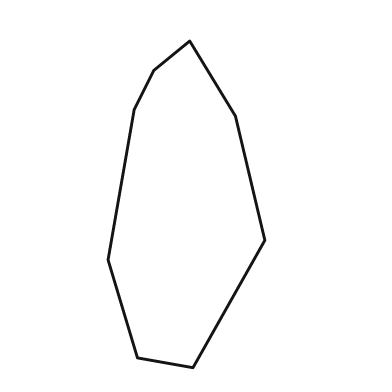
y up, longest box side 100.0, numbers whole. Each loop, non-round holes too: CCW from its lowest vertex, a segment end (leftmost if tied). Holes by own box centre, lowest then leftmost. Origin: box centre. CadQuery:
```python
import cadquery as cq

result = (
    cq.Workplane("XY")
    .moveTo(2.0, -50.0)
    .lineTo(24.0, -11.0)
    .lineTo(15.0, 27.0)
    .lineTo(1.0, 50.0)
    .lineTo(-10.0, 41.0)
    .lineTo(-16.0, 29.0)
    .lineTo(-24.0, -17.0)
    .lineTo(-15.0, -47.0)
    .close()
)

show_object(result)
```